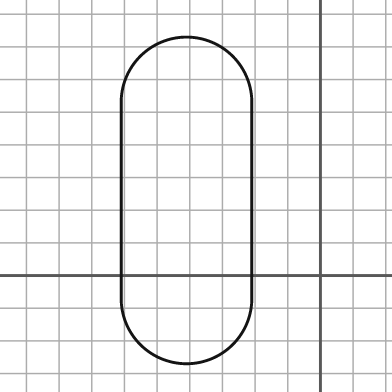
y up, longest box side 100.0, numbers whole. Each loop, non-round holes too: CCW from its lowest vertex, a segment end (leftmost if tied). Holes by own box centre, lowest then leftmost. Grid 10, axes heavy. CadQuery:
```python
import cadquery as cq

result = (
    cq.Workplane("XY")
    .moveTo(-61.0, -7.0)
    .threePointArc((-41.0, -27.0), (-21.0, -7.0))
    .lineTo(-21.0, 53.0)
    .threePointArc((-41.0, 73.0), (-61.0, 53.0))
    .close()
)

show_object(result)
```